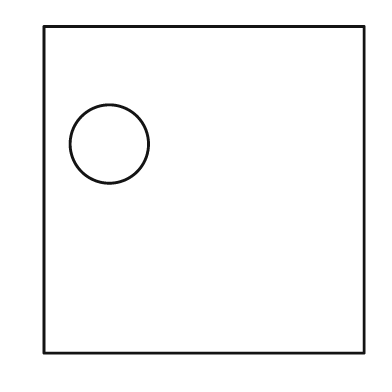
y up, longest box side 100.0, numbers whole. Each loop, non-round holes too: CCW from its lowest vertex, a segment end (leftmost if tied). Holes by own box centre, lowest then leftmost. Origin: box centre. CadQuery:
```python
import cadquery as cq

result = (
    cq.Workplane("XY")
    .moveTo(-49.0, -50.0)
    .lineTo(49.0, -50.0)
    .lineTo(49.0, 50.0)
    .lineTo(-49.0, 50.0)
    .close()
    .moveTo(-29.0, 14.0)
    .circle(12.0)
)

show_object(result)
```